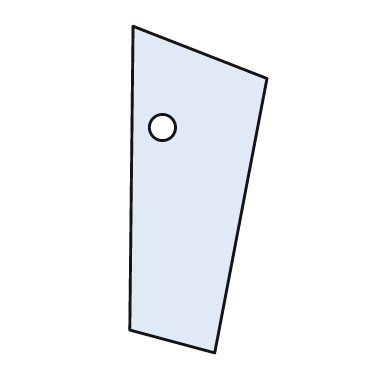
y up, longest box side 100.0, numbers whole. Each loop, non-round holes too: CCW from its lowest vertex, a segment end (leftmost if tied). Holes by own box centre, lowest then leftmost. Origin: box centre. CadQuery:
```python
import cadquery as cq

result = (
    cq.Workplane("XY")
    .moveTo(5.0, -50.0)
    .lineTo(21.0, 34.0)
    .lineTo(-20.0, 50.0)
    .lineTo(-21.0, -43.0)
    .close()
    .moveTo(-11.0, 19.0)
    .circle(4.0)
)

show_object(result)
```